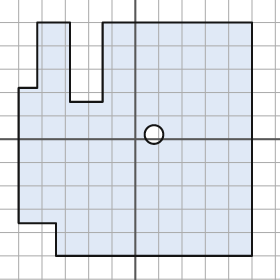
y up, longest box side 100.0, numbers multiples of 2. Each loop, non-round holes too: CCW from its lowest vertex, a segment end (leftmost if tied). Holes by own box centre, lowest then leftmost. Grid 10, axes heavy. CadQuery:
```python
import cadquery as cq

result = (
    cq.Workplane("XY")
    .moveTo(-34.0, -50.0)
    .lineTo(50.0, -50.0)
    .lineTo(50.0, 50.0)
    .lineTo(-14.0, 50.0)
    .lineTo(-14.0, 16.0)
    .lineTo(-28.0, 16.0)
    .lineTo(-28.0, 50.0)
    .lineTo(-42.0, 50.0)
    .lineTo(-42.0, 22.0)
    .lineTo(-50.0, 22.0)
    .lineTo(-50.0, -36.0)
    .lineTo(-34.0, -36.0)
    .close()
    .moveTo(8.0, 2.0)
    .circle(4.0)
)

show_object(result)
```